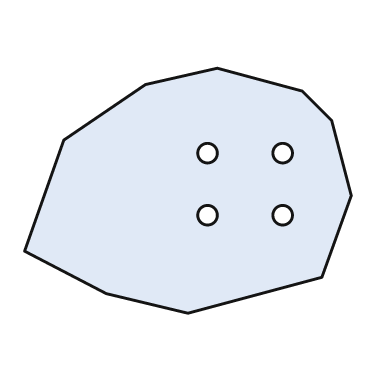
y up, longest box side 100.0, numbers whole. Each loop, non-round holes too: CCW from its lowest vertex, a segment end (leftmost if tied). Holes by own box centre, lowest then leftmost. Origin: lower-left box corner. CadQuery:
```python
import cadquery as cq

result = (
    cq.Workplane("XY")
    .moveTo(50.0, 0.0)
    .lineTo(91.0, 11.0)
    .lineTo(100.0, 36.0)
    .lineTo(94.0, 59.0)
    .lineTo(85.0, 68.0)
    .lineTo(59.0, 75.0)
    .lineTo(37.0, 70.0)
    .lineTo(12.0, 53.0)
    .lineTo(0.0, 19.0)
    .lineTo(25.0, 6.0)
    .close()
    .moveTo(56.0, 30.0)
    .circle(3.0)
    .moveTo(79.0, 30.0)
    .circle(3.0)
    .moveTo(56.0, 49.0)
    .circle(3.0)
    .moveTo(79.0, 49.0)
    .circle(3.0)
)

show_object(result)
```